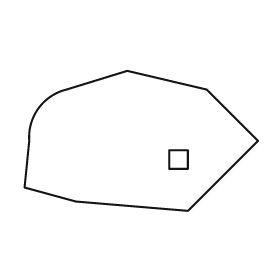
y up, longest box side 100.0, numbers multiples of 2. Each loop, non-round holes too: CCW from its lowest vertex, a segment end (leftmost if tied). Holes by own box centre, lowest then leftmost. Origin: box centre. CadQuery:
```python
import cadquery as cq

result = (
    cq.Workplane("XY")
    .moveTo(20.0, -30.0)
    .lineTo(50.0, 0.0)
    .lineTo(28.0, 22.0)
    .lineTo(-6.0, 30.0)
    .lineTo(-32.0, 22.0)
    .threePointArc((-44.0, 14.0), (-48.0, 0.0))
    .lineTo(-50.0, -20.0)
    .lineTo(-28.0, -26.0)
    .close()
    .moveTo(12.0, -12.0)
    .lineTo(20.0, -12.0)
    .lineTo(20.0, -4.0)
    .lineTo(12.0, -4.0)
    .close()
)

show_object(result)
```